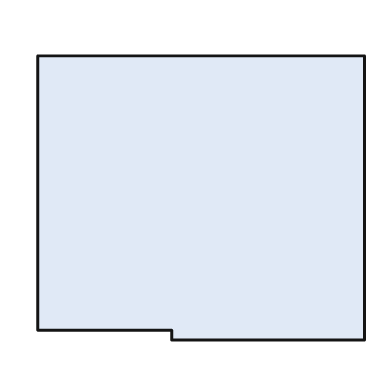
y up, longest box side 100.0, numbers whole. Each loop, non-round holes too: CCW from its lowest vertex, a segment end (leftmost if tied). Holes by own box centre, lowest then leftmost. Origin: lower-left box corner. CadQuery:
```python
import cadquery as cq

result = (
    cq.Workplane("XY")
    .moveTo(41.0, 0.0)
    .lineTo(100.0, 0.0)
    .lineTo(100.0, 87.0)
    .lineTo(0.0, 87.0)
    .lineTo(0.0, 3.0)
    .lineTo(41.0, 3.0)
    .close()
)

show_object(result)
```